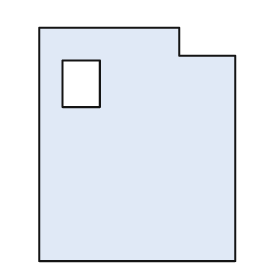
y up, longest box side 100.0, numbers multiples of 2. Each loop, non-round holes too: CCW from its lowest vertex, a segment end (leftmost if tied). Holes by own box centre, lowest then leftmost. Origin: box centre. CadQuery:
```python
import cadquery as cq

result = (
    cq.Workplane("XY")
    .moveTo(-42.0, -50.0)
    .lineTo(42.0, -50.0)
    .lineTo(42.0, 38.0)
    .lineTo(18.0, 38.0)
    .lineTo(18.0, 50.0)
    .lineTo(-42.0, 50.0)
    .close()
    .moveTo(-32.0, 16.0)
    .lineTo(-16.0, 16.0)
    .lineTo(-16.0, 36.0)
    .lineTo(-32.0, 36.0)
    .close()
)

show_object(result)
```